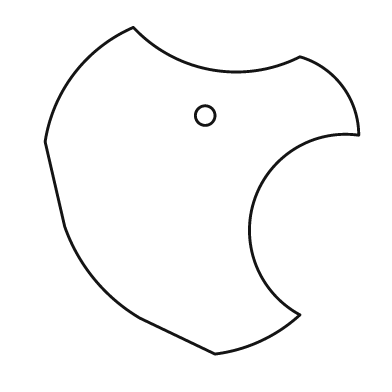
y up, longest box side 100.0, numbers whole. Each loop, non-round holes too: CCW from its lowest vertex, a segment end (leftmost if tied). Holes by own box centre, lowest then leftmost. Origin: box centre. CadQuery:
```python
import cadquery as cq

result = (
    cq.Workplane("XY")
    .moveTo(4.0, -50.0)
    .threePointArc((18.0, -46.0), (30.0, -38.0))
    .threePointArc((16.0, -3.0), (48.0, 17.0))
    .threePointArc((43.0, 32.0), (30.0, 41.0))
    .threePointArc((3.0, 37.0), (-21.0, 50.0))
    .threePointArc((-39.0, 36.0), (-48.0, 15.0))
    .lineTo(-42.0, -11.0)
    .threePointArc((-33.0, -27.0), (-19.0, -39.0))
    .close()
    .moveTo(1.0, 23.0)
    .circle(3.0)
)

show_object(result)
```